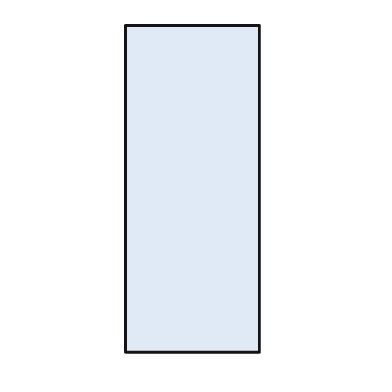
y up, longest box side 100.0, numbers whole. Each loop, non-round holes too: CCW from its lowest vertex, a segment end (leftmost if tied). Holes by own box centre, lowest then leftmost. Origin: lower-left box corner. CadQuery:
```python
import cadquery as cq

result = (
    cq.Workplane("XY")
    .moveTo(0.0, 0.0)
    .lineTo(41.0, 0.0)
    .lineTo(41.0, 100.0)
    .lineTo(0.0, 100.0)
    .close()
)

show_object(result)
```